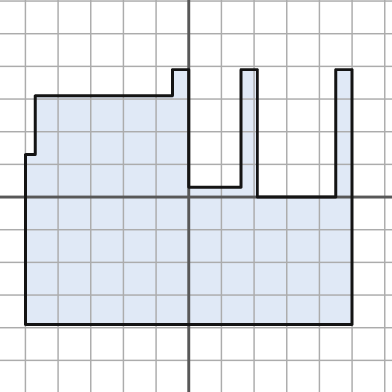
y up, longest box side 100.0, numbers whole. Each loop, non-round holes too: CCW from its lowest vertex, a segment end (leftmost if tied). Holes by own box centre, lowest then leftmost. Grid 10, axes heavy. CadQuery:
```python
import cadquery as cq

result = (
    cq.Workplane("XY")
    .moveTo(-50.0, -39.0)
    .lineTo(50.0, -39.0)
    .lineTo(50.0, 39.0)
    .lineTo(45.0, 39.0)
    .lineTo(45.0, 0.0)
    .lineTo(21.0, 0.0)
    .lineTo(21.0, 39.0)
    .lineTo(16.0, 39.0)
    .lineTo(16.0, 3.0)
    .lineTo(0.0, 3.0)
    .lineTo(0.0, 39.0)
    .lineTo(-5.0, 39.0)
    .lineTo(-5.0, 31.0)
    .lineTo(-47.0, 31.0)
    .lineTo(-47.0, 13.0)
    .lineTo(-50.0, 13.0)
    .close()
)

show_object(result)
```